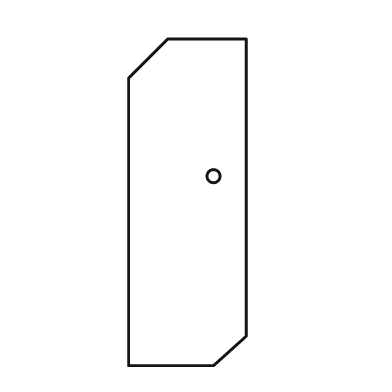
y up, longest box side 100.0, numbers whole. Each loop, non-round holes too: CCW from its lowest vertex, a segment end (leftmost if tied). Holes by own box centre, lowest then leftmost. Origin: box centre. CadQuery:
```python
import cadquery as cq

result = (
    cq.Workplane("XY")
    .moveTo(-18.0, -50.0)
    .lineTo(8.0, -50.0)
    .lineTo(18.0, -41.0)
    .lineTo(18.0, 50.0)
    .lineTo(-6.0, 50.0)
    .lineTo(-18.0, 38.0)
    .close()
    .moveTo(8.0, 8.0)
    .circle(2.0)
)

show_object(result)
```